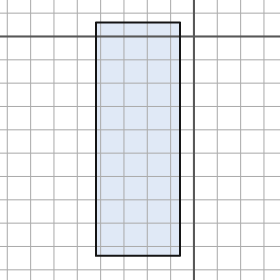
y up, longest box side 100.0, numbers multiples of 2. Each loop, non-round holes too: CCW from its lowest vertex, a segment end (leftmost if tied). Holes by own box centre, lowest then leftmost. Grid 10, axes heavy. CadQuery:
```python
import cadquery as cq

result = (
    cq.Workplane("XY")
    .moveTo(-42.0, -94.0)
    .lineTo(-6.0, -94.0)
    .lineTo(-6.0, 6.0)
    .lineTo(-42.0, 6.0)
    .close()
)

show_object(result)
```